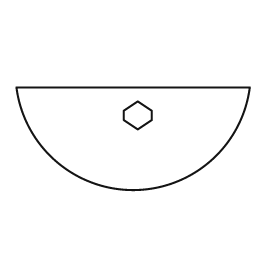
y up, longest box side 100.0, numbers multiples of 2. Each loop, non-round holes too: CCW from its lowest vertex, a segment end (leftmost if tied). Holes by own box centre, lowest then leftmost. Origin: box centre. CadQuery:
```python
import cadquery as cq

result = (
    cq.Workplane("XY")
    .moveTo(-50.0, 22.0)
    .threePointArc((0.0, -22.0), (50.0, 22.0))
    .close()
    .moveTo(2.0, 4.0)
    .lineTo(8.0, 8.0)
    .lineTo(8.0, 12.0)
    .lineTo(2.0, 16.0)
    .lineTo(-4.0, 12.0)
    .lineTo(-4.0, 8.0)
    .close()
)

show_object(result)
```